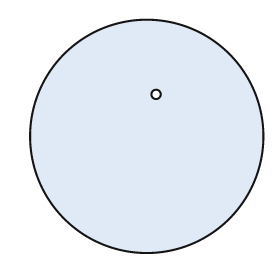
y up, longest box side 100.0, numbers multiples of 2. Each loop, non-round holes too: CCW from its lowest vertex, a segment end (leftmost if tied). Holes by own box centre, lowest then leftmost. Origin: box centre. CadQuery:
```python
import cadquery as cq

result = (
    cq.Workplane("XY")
    .moveTo(0.0, 0.0)
    .circle(50.0)
    .moveTo(4.0, 18.0)
    .circle(2.0)
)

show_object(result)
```